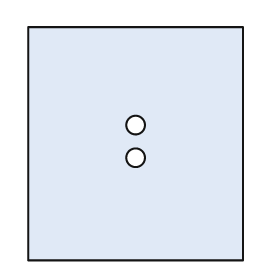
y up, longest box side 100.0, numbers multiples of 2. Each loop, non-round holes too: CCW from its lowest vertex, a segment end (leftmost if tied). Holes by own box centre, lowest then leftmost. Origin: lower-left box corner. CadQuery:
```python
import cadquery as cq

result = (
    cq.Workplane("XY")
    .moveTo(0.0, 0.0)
    .lineTo(92.0, 0.0)
    .lineTo(92.0, 100.0)
    .lineTo(0.0, 100.0)
    .close()
    .moveTo(46.0, 44.0)
    .circle(4.0)
    .moveTo(46.0, 58.0)
    .circle(4.0)
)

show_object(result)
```